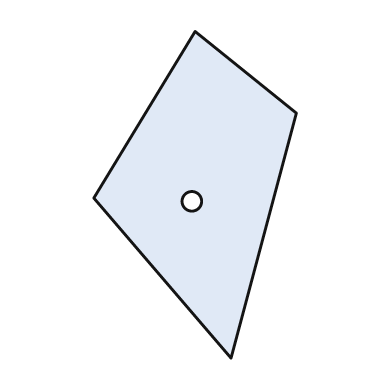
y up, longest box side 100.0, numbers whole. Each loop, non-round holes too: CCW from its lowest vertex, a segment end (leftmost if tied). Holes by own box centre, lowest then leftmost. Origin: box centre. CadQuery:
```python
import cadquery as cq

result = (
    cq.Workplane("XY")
    .moveTo(11.0, -50.0)
    .lineTo(31.0, 25.0)
    .lineTo(0.0, 50.0)
    .lineTo(-31.0, -1.0)
    .close()
    .moveTo(-1.0, -2.0)
    .circle(3.0)
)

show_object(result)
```